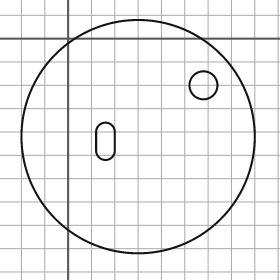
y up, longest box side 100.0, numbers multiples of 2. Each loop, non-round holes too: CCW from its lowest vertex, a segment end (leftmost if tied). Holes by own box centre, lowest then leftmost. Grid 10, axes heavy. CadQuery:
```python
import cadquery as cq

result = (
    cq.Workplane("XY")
    .moveTo(30.0, -42.0)
    .circle(50.0)
    .moveTo(12.0, -48.0)
    .threePointArc((16.0, -52.0), (20.0, -48.0))
    .lineTo(20.0, -40.0)
    .threePointArc((16.0, -36.0), (12.0, -40.0))
    .close()
    .moveTo(58.0, -20.0)
    .circle(6.0)
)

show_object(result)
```